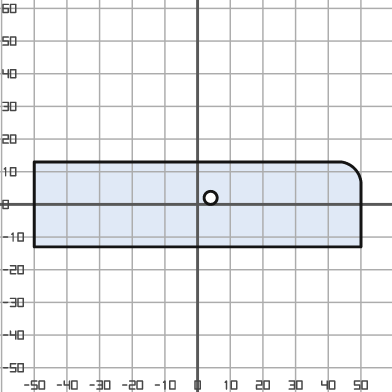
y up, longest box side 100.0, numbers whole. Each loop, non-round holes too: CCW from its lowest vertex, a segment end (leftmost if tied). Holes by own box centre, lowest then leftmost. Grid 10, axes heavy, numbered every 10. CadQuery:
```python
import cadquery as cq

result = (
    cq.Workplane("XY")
    .moveTo(-50.0, -13.0)
    .lineTo(50.0, -13.0)
    .lineTo(50.0, 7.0)
    .threePointArc((48.0, 11.0), (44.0, 13.0))
    .lineTo(-50.0, 13.0)
    .close()
    .moveTo(4.0, 2.0)
    .circle(2.0)
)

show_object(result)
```